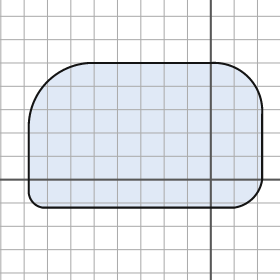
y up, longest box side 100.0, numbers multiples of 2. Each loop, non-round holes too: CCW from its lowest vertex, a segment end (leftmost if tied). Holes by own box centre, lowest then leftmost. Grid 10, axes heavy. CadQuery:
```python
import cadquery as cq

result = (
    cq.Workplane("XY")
    .moveTo(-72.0, -12.0)
    .lineTo(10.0, -12.0)
    .threePointArc((18.0, -8.0), (22.0, 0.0))
    .lineTo(22.0, 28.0)
    .threePointArc((16.0, 44.0), (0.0, 50.0))
    .lineTo(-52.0, 50.0)
    .threePointArc((-70.0, 42.0), (-78.0, 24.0))
    .lineTo(-78.0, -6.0)
    .threePointArc((-76.0, -10.0), (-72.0, -12.0))
    .close()
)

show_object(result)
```